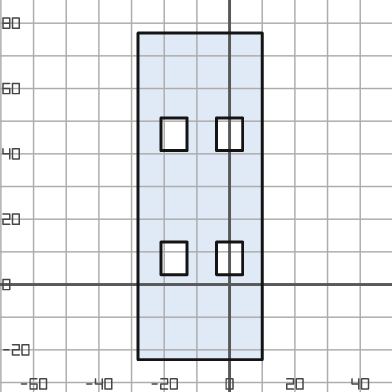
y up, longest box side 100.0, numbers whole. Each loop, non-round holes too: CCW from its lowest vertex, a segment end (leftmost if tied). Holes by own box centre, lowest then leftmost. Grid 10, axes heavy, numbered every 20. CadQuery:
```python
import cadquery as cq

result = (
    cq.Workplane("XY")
    .moveTo(-28.0, -23.0)
    .lineTo(10.0, -23.0)
    .lineTo(10.0, 77.0)
    .lineTo(-28.0, 77.0)
    .close()
    .moveTo(-21.0, 3.0)
    .lineTo(-13.0, 3.0)
    .lineTo(-13.0, 13.0)
    .lineTo(-21.0, 13.0)
    .close()
    .moveTo(-4.0, 3.0)
    .lineTo(4.0, 3.0)
    .lineTo(4.0, 13.0)
    .lineTo(-4.0, 13.0)
    .close()
    .moveTo(-21.0, 41.0)
    .lineTo(-13.0, 41.0)
    .lineTo(-13.0, 51.0)
    .lineTo(-21.0, 51.0)
    .close()
    .moveTo(-4.0, 41.0)
    .lineTo(4.0, 41.0)
    .lineTo(4.0, 51.0)
    .lineTo(-4.0, 51.0)
    .close()
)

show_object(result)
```